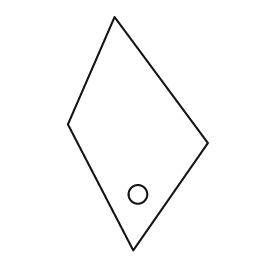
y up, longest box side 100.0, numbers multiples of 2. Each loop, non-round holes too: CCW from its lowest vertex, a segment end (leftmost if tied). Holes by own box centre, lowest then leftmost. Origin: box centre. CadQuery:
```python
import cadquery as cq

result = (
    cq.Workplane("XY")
    .moveTo(-2.0, -50.0)
    .lineTo(30.0, -4.0)
    .lineTo(-10.0, 50.0)
    .lineTo(-30.0, 4.0)
    .close()
    .moveTo(0.0, -26.0)
    .circle(4.0)
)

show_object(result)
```